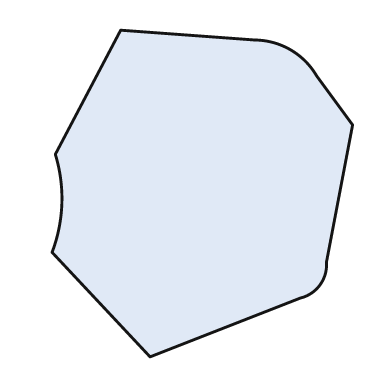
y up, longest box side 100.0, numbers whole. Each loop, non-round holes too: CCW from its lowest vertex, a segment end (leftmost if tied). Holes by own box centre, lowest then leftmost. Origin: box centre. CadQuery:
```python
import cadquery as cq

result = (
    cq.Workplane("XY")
    .moveTo(-16.0, -50.0)
    .lineTo(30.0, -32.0)
    .threePointArc((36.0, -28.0), (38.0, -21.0))
    .lineTo(46.0, 21.0)
    .lineTo(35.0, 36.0)
    .threePointArc((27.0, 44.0), (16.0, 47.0))
    .lineTo(-25.0, 50.0)
    .lineTo(-45.0, 12.0)
    .threePointArc((-43.0, -3.0), (-46.0, -18.0))
    .close()
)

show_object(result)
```